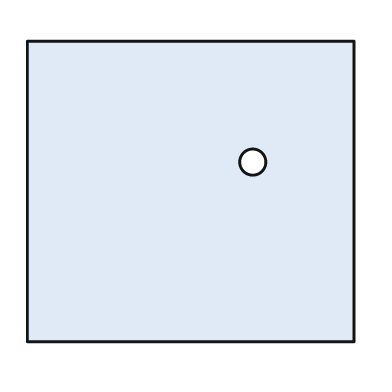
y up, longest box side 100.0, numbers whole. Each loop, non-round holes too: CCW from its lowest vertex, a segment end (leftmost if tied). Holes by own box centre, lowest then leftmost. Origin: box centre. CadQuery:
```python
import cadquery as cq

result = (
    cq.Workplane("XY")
    .moveTo(-50.0, -46.0)
    .lineTo(50.0, -46.0)
    .lineTo(50.0, 46.0)
    .lineTo(-50.0, 46.0)
    .close()
    .moveTo(19.0, 9.0)
    .circle(4.0)
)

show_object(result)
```